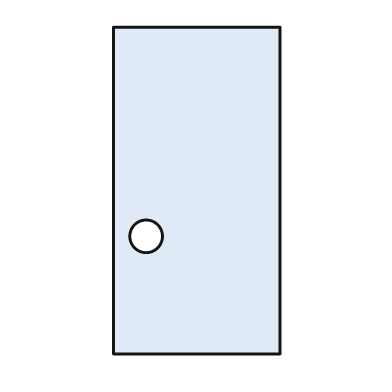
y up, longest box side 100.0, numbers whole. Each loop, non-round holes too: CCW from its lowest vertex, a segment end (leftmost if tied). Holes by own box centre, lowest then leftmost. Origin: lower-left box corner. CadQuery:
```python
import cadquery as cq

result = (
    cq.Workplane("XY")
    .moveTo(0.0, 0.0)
    .lineTo(51.0, 0.0)
    .lineTo(51.0, 100.0)
    .lineTo(0.0, 100.0)
    .close()
    .moveTo(10.0, 36.0)
    .circle(5.0)
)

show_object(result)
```